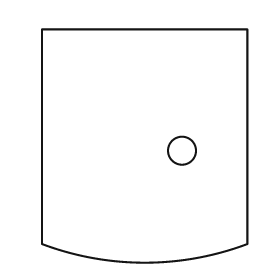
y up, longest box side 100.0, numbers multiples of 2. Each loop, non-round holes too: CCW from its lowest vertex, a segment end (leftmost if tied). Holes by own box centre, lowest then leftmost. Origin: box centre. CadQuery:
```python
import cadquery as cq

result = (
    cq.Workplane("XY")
    .moveTo(-44.0, -42.0)
    .threePointArc((0.0, -50.0), (44.0, -42.0))
    .lineTo(44.0, 50.0)
    .lineTo(-44.0, 50.0)
    .close()
    .moveTo(16.0, -2.0)
    .circle(6.0)
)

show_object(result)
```